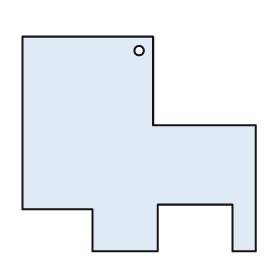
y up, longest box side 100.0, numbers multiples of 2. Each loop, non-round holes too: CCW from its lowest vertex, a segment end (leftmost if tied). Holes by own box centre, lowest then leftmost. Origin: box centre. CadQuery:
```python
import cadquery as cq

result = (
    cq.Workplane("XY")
    .moveTo(-20.0, -46.0)
    .lineTo(8.0, -46.0)
    .lineTo(8.0, -26.0)
    .lineTo(40.0, -26.0)
    .lineTo(40.0, -46.0)
    .lineTo(50.0, -46.0)
    .lineTo(50.0, 8.0)
    .lineTo(6.0, 8.0)
    .lineTo(6.0, 46.0)
    .lineTo(-50.0, 46.0)
    .lineTo(-50.0, -28.0)
    .lineTo(-20.0, -28.0)
    .close()
    .moveTo(0.0, 40.0)
    .circle(2.0)
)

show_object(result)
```